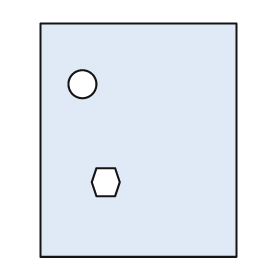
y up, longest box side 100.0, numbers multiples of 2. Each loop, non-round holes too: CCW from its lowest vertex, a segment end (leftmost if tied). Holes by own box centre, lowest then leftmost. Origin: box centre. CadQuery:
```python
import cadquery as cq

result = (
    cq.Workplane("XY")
    .moveTo(-42.0, -50.0)
    .lineTo(42.0, -50.0)
    .lineTo(42.0, 50.0)
    .lineTo(-42.0, 50.0)
    .close()
    .moveTo(-18.0, -24.0)
    .lineTo(-10.0, -24.0)
    .lineTo(-8.0, -18.0)
    .lineTo(-10.0, -12.0)
    .lineTo(-18.0, -12.0)
    .lineTo(-20.0, -18.0)
    .close()
    .moveTo(-24.0, 24.0)
    .circle(6.0)
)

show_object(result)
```